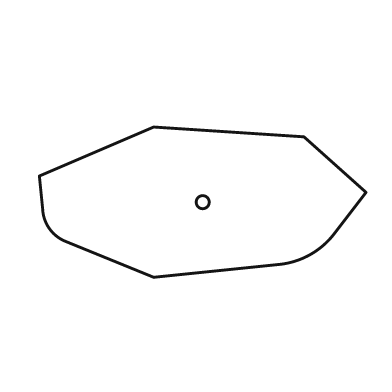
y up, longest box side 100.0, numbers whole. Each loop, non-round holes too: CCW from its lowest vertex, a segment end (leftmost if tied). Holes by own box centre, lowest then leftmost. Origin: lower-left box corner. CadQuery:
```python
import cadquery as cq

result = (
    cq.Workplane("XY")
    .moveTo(35.0, 0.0)
    .lineTo(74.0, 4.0)
    .threePointArc((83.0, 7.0), (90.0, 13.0))
    .lineTo(100.0, 26.0)
    .lineTo(81.0, 43.0)
    .lineTo(35.0, 46.0)
    .lineTo(0.0, 31.0)
    .lineTo(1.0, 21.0)
    .threePointArc((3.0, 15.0), (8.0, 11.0))
    .close()
    .moveTo(50.0, 23.0)
    .circle(2.0)
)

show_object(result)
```